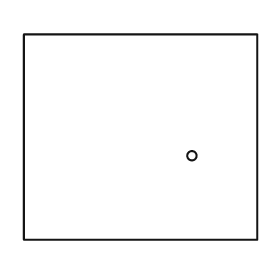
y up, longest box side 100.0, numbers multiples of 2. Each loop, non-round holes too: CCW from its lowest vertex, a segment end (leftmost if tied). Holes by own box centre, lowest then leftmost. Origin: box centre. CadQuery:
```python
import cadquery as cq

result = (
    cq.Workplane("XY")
    .moveTo(-50.0, -44.0)
    .lineTo(50.0, -44.0)
    .lineTo(50.0, 44.0)
    .lineTo(-50.0, 44.0)
    .close()
    .moveTo(22.0, -8.0)
    .circle(2.0)
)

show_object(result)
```